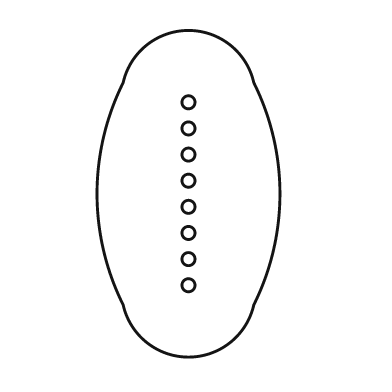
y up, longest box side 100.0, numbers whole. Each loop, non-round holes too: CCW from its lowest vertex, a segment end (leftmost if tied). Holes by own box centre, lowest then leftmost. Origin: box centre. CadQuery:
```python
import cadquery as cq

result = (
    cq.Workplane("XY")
    .moveTo(-20.0, -34.0)
    .threePointArc((0.0, -50.0), (20.0, -34.0))
    .threePointArc((28.0, 0.0), (20.0, 34.0))
    .threePointArc((0.0, 50.0), (-20.0, 34.0))
    .threePointArc((-28.0, 0.0), (-20.0, -34.0))
    .close()
    .moveTo(0.0, -28.0)
    .circle(2.0)
    .moveTo(0.0, -20.0)
    .circle(2.0)
    .moveTo(0.0, -12.0)
    .circle(2.0)
    .moveTo(0.0, -4.0)
    .circle(2.0)
    .moveTo(0.0, 4.0)
    .circle(2.0)
    .moveTo(0.0, 12.0)
    .circle(2.0)
    .moveTo(0.0, 20.0)
    .circle(2.0)
    .moveTo(0.0, 28.0)
    .circle(2.0)
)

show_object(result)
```